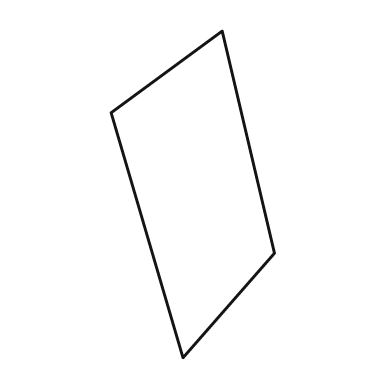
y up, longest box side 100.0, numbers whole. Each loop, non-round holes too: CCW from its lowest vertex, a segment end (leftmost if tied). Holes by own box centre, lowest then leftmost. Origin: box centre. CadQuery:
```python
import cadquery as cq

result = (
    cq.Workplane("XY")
    .moveTo(-3.0, -50.0)
    .lineTo(25.0, -18.0)
    .lineTo(9.0, 50.0)
    .lineTo(-25.0, 25.0)
    .close()
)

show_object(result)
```